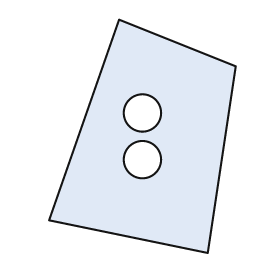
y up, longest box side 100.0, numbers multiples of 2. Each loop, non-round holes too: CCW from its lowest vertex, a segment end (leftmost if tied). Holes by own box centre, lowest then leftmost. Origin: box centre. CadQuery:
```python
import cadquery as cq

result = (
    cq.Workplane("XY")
    .moveTo(28.0, -50.0)
    .lineTo(40.0, 30.0)
    .lineTo(-10.0, 50.0)
    .lineTo(-40.0, -36.0)
    .close()
    .moveTo(0.0, -10.0)
    .circle(8.0)
    .moveTo(0.0, 10.0)
    .circle(8.0)
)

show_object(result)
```